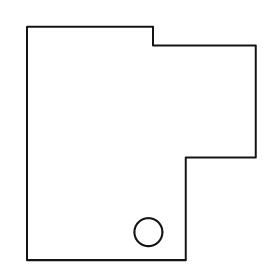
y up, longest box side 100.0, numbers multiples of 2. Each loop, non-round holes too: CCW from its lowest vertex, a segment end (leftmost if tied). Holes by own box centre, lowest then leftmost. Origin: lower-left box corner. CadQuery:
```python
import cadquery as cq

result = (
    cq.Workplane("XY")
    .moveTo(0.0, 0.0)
    .lineTo(68.0, 0.0)
    .lineTo(68.0, 44.0)
    .lineTo(98.0, 44.0)
    .lineTo(98.0, 92.0)
    .lineTo(54.0, 92.0)
    .lineTo(54.0, 100.0)
    .lineTo(0.0, 100.0)
    .close()
    .moveTo(52.0, 12.0)
    .circle(6.0)
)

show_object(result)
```